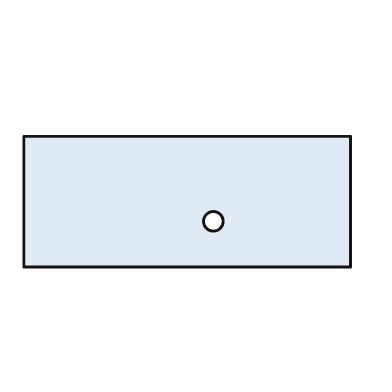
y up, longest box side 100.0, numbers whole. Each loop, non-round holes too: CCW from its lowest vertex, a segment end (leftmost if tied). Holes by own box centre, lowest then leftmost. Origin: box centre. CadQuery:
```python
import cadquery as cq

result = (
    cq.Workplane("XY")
    .moveTo(-50.0, -20.0)
    .lineTo(50.0, -20.0)
    .lineTo(50.0, 20.0)
    .lineTo(-50.0, 20.0)
    .close()
    .moveTo(8.0, -6.0)
    .circle(3.0)
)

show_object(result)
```